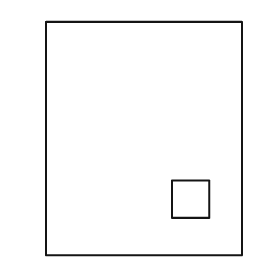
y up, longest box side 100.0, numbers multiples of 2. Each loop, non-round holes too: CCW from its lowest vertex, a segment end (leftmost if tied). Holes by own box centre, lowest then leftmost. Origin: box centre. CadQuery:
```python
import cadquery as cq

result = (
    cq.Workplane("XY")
    .moveTo(-42.0, -50.0)
    .lineTo(42.0, -50.0)
    .lineTo(42.0, 50.0)
    .lineTo(-42.0, 50.0)
    .close()
    .moveTo(12.0, -34.0)
    .lineTo(28.0, -34.0)
    .lineTo(28.0, -18.0)
    .lineTo(12.0, -18.0)
    .close()
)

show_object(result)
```